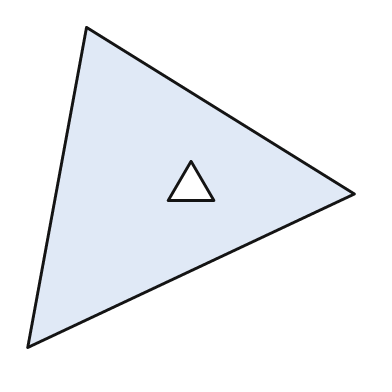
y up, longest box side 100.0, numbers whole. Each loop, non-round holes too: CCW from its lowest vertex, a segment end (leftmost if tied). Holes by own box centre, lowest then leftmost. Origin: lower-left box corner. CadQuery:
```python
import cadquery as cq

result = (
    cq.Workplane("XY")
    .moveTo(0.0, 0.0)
    .lineTo(100.0, 47.0)
    .lineTo(18.0, 98.0)
    .close()
    .moveTo(43.0, 45.0)
    .lineTo(57.0, 45.0)
    .lineTo(50.0, 57.0)
    .close()
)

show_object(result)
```